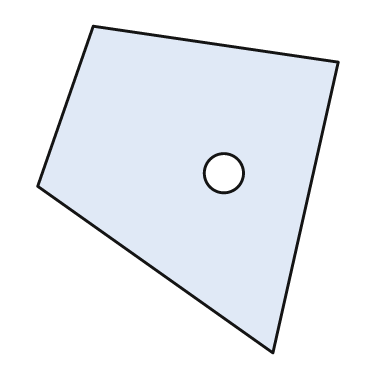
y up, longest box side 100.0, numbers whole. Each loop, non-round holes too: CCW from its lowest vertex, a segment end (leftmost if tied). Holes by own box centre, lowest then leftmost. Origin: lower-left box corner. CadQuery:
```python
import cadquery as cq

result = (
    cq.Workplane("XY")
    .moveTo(72.0, 0.0)
    .lineTo(92.0, 89.0)
    .lineTo(17.0, 100.0)
    .lineTo(0.0, 51.0)
    .close()
    .moveTo(57.0, 55.0)
    .circle(6.0)
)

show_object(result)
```